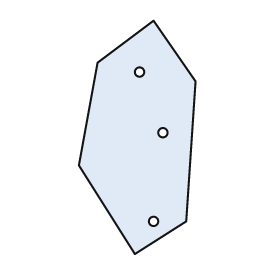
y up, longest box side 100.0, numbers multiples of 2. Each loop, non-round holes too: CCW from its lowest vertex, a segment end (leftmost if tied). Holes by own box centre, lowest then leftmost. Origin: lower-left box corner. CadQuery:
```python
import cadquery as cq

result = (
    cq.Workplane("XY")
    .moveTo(24.0, 0.0)
    .lineTo(46.0, 14.0)
    .lineTo(50.0, 74.0)
    .lineTo(32.0, 100.0)
    .lineTo(8.0, 82.0)
    .lineTo(0.0, 38.0)
    .close()
    .moveTo(32.0, 14.0)
    .circle(2.0)
    .moveTo(36.0, 52.0)
    .circle(2.0)
    .moveTo(26.0, 78.0)
    .circle(2.0)
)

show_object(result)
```